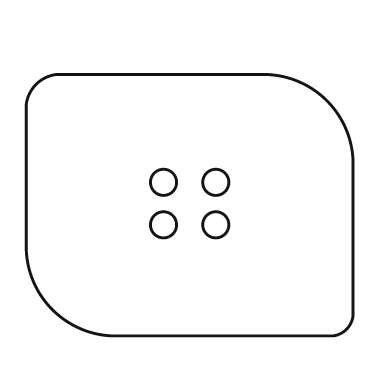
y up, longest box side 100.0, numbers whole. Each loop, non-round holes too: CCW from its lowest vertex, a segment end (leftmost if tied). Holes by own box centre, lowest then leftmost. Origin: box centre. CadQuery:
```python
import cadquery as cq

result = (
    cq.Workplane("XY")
    .moveTo(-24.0, -40.0)
    .lineTo(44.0, -40.0)
    .threePointArc((48.0, -38.0), (50.0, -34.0))
    .lineTo(50.0, 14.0)
    .threePointArc((42.0, 32.0), (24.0, 40.0))
    .lineTo(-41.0, 40.0)
    .threePointArc((-47.0, 37.0), (-50.0, 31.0))
    .lineTo(-50.0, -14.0)
    .threePointArc((-42.0, -32.0), (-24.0, -40.0))
    .close()
    .moveTo(-8.0, -6.0)
    .circle(4.0)
    .moveTo(8.0, -6.0)
    .circle(4.0)
    .moveTo(-8.0, 7.0)
    .circle(4.0)
    .moveTo(8.0, 7.0)
    .circle(4.0)
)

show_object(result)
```